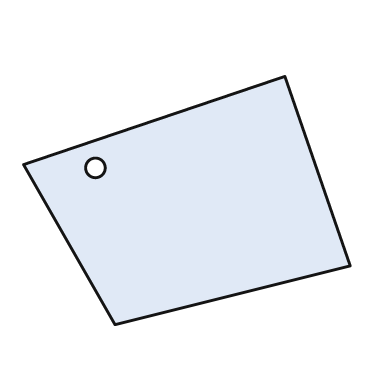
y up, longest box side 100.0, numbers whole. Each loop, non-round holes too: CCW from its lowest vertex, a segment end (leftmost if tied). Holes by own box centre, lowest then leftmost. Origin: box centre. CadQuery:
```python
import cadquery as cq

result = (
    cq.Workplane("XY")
    .moveTo(-22.0, -38.0)
    .lineTo(50.0, -20.0)
    .lineTo(30.0, 38.0)
    .lineTo(-50.0, 11.0)
    .close()
    .moveTo(-28.0, 10.0)
    .circle(3.0)
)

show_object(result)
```